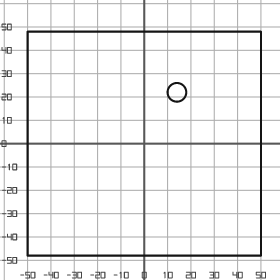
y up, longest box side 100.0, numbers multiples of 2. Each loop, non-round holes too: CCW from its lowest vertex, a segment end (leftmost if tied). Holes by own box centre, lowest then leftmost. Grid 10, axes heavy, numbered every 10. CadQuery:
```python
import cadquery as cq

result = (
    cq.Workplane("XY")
    .moveTo(-50.0, -48.0)
    .lineTo(50.0, -48.0)
    .lineTo(50.0, 48.0)
    .lineTo(-50.0, 48.0)
    .close()
    .moveTo(14.0, 22.0)
    .circle(4.0)
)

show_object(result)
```